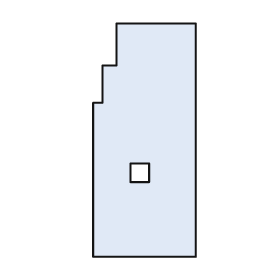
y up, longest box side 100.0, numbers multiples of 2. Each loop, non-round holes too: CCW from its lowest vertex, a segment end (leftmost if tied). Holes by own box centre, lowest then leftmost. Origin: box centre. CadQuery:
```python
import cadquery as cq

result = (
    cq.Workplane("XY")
    .moveTo(-22.0, -50.0)
    .lineTo(22.0, -50.0)
    .lineTo(22.0, 50.0)
    .lineTo(-12.0, 50.0)
    .lineTo(-12.0, 32.0)
    .lineTo(-18.0, 32.0)
    .lineTo(-18.0, 16.0)
    .lineTo(-22.0, 16.0)
    .close()
    .moveTo(-6.0, -18.0)
    .lineTo(2.0, -18.0)
    .lineTo(2.0, -10.0)
    .lineTo(-6.0, -10.0)
    .close()
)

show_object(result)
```